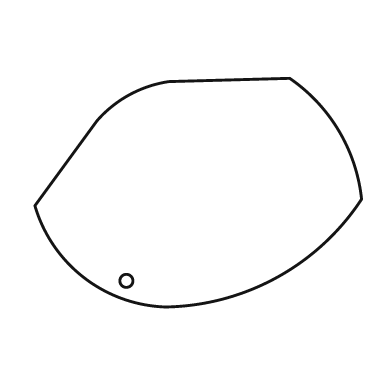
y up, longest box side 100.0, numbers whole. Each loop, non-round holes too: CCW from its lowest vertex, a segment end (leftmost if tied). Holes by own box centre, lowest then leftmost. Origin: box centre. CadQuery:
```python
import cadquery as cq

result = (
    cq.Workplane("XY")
    .moveTo(-10.0, -35.0)
    .threePointArc((24.0, -26.0), (50.0, -2.0))
    .threePointArc((43.0, 19.0), (28.0, 35.0))
    .lineTo(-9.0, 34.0)
    .threePointArc((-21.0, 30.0), (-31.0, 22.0))
    .lineTo(-50.0, -4.0)
    .threePointArc((-35.0, -26.0), (-10.0, -35.0))
    .close()
    .moveTo(-22.0, -27.0)
    .circle(2.0)
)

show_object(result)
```